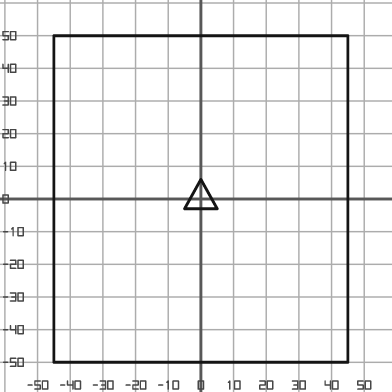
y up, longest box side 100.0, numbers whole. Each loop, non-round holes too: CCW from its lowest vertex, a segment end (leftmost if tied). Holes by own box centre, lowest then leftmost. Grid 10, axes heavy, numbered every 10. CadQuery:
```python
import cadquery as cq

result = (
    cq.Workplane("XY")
    .moveTo(-45.0, -50.0)
    .lineTo(45.0, -50.0)
    .lineTo(45.0, 50.0)
    .lineTo(-45.0, 50.0)
    .close()
    .moveTo(-5.0, -3.0)
    .lineTo(5.0, -3.0)
    .lineTo(0.0, 6.0)
    .close()
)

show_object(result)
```